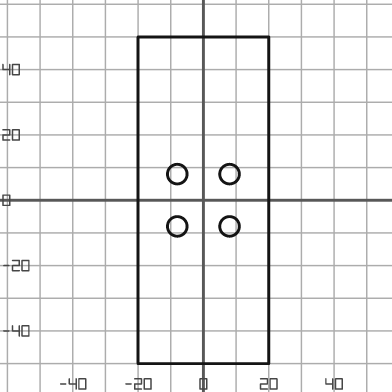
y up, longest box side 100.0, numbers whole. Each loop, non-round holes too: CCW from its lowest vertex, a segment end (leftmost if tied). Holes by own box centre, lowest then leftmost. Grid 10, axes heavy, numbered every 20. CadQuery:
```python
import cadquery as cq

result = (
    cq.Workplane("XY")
    .moveTo(-20.0, -50.0)
    .lineTo(20.0, -50.0)
    .lineTo(20.0, 50.0)
    .lineTo(-20.0, 50.0)
    .close()
    .moveTo(-8.0, -8.0)
    .circle(3.0)
    .moveTo(8.0, -8.0)
    .circle(3.0)
    .moveTo(-8.0, 8.0)
    .circle(3.0)
    .moveTo(8.0, 8.0)
    .circle(3.0)
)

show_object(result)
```